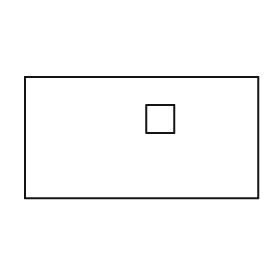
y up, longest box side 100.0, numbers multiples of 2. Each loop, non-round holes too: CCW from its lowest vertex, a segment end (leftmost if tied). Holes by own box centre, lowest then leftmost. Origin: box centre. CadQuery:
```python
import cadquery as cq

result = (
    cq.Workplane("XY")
    .moveTo(-50.0, -26.0)
    .lineTo(50.0, -26.0)
    .lineTo(50.0, 26.0)
    .lineTo(-50.0, 26.0)
    .close()
    .moveTo(2.0, 2.0)
    .lineTo(14.0, 2.0)
    .lineTo(14.0, 14.0)
    .lineTo(2.0, 14.0)
    .close()
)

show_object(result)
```